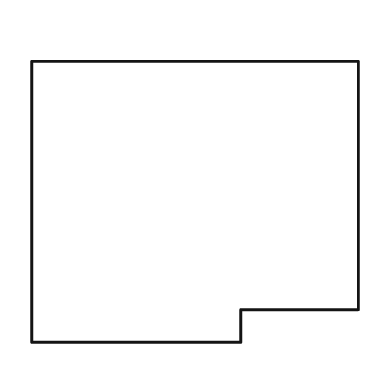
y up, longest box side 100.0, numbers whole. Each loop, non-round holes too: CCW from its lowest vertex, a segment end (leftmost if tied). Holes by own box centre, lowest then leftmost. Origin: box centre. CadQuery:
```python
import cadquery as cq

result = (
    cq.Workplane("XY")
    .moveTo(-50.0, -43.0)
    .lineTo(14.0, -43.0)
    .lineTo(14.0, -33.0)
    .lineTo(50.0, -33.0)
    .lineTo(50.0, 43.0)
    .lineTo(-50.0, 43.0)
    .close()
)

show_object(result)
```